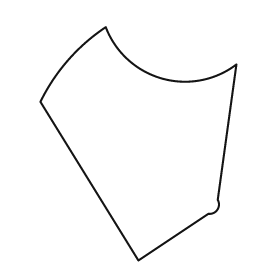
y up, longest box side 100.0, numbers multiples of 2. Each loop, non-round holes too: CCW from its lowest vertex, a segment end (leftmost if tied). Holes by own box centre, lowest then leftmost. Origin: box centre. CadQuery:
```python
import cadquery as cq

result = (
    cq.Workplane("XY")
    .moveTo(0.0, -50.0)
    .lineTo(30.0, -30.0)
    .threePointArc((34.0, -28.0), (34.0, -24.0))
    .lineTo(42.0, 34.0)
    .threePointArc((10.0, 28.0), (-14.0, 50.0))
    .threePointArc((-30.0, 36.0), (-42.0, 18.0))
    .close()
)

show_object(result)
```